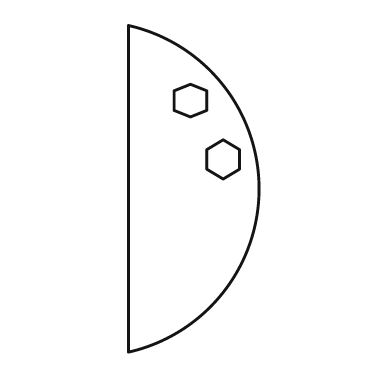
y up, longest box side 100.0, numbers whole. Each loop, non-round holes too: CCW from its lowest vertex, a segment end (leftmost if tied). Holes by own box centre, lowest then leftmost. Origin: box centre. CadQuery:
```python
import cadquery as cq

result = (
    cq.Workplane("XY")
    .moveTo(-20.0, -50.0)
    .threePointArc((20.0, 0.0), (-20.0, 50.0))
    .close()
    .moveTo(9.0, 3.0)
    .lineTo(14.0, 6.0)
    .lineTo(14.0, 12.0)
    .lineTo(9.0, 15.0)
    .lineTo(4.0, 12.0)
    .lineTo(4.0, 6.0)
    .close()
    .moveTo(-1.0, 22.0)
    .lineTo(4.0, 24.0)
    .lineTo(4.0, 30.0)
    .lineTo(-1.0, 32.0)
    .lineTo(-6.0, 30.0)
    .lineTo(-6.0, 24.0)
    .close()
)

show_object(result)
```